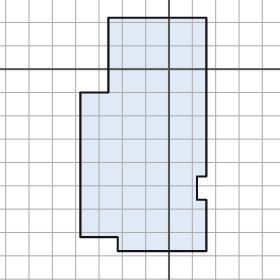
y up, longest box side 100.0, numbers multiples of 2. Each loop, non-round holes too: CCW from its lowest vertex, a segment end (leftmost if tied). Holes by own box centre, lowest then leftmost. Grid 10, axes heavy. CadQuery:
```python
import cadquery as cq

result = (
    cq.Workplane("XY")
    .moveTo(-22.0, -78.0)
    .lineTo(16.0, -78.0)
    .lineTo(16.0, -56.0)
    .lineTo(12.0, -56.0)
    .lineTo(12.0, -46.0)
    .lineTo(16.0, -46.0)
    .lineTo(16.0, 22.0)
    .lineTo(-26.0, 22.0)
    .lineTo(-26.0, -10.0)
    .lineTo(-38.0, -10.0)
    .lineTo(-38.0, -72.0)
    .lineTo(-22.0, -72.0)
    .close()
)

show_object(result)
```